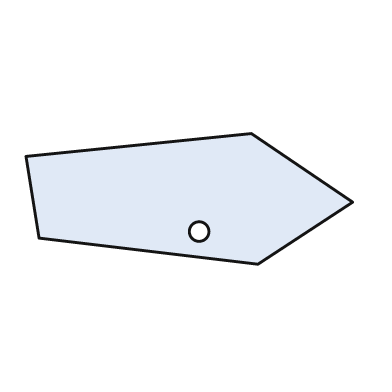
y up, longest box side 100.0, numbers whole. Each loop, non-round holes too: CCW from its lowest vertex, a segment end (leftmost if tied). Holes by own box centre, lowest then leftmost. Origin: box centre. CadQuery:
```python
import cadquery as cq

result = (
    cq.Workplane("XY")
    .moveTo(21.0, -20.0)
    .lineTo(50.0, -1.0)
    .lineTo(19.0, 20.0)
    .lineTo(-50.0, 13.0)
    .lineTo(-46.0, -12.0)
    .close()
    .moveTo(3.0, -10.0)
    .circle(3.0)
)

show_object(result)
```